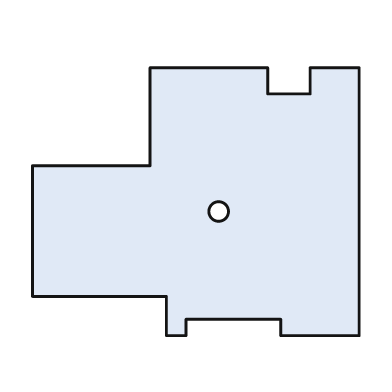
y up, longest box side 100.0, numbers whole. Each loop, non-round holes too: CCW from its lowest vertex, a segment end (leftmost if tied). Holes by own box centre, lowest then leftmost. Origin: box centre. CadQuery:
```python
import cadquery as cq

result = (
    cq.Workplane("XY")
    .moveTo(-9.0, -41.0)
    .lineTo(-3.0, -41.0)
    .lineTo(-3.0, -36.0)
    .lineTo(26.0, -36.0)
    .lineTo(26.0, -41.0)
    .lineTo(50.0, -41.0)
    .lineTo(50.0, 41.0)
    .lineTo(35.0, 41.0)
    .lineTo(35.0, 33.0)
    .lineTo(22.0, 33.0)
    .lineTo(22.0, 41.0)
    .lineTo(-14.0, 41.0)
    .lineTo(-14.0, 11.0)
    .lineTo(-50.0, 11.0)
    .lineTo(-50.0, -29.0)
    .lineTo(-9.0, -29.0)
    .close()
    .moveTo(7.0, -3.0)
    .circle(3.0)
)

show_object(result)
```